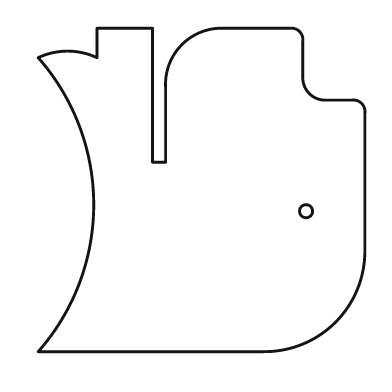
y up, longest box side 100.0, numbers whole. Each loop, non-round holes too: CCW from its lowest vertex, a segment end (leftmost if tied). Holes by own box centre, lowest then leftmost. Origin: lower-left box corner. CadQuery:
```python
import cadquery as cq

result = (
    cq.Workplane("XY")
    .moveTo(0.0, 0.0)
    .lineTo(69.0, 0.0)
    .threePointArc((91.0, 9.0), (100.0, 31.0))
    .lineTo(100.0, 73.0)
    .threePointArc((99.0, 76.0), (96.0, 77.0))
    .lineTo(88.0, 77.0)
    .threePointArc((83.0, 79.0), (81.0, 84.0))
    .lineTo(81.0, 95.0)
    .threePointArc((80.0, 98.0), (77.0, 99.0))
    .lineTo(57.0, 99.0)
    .threePointArc((44.0, 94.0), (39.0, 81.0))
    .lineTo(39.0, 58.0)
    .lineTo(35.0, 58.0)
    .lineTo(35.0, 99.0)
    .lineTo(18.0, 99.0)
    .lineTo(18.0, 90.0)
    .threePointArc((9.0, 92.0), (0.0, 90.0))
    .threePointArc((17.0, 45.0), (0.0, 0.0))
    .close()
    .moveTo(82.0, 43.0)
    .circle(2.0)
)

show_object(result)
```